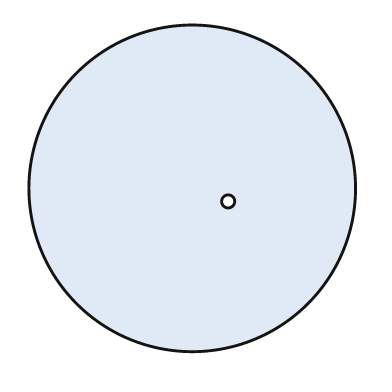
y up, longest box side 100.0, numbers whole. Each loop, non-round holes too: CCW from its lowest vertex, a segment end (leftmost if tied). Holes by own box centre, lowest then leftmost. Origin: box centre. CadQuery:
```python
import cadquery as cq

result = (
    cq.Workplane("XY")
    .moveTo(0.0, 0.0)
    .circle(50.0)
    .moveTo(11.0, -4.0)
    .circle(2.0)
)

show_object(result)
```